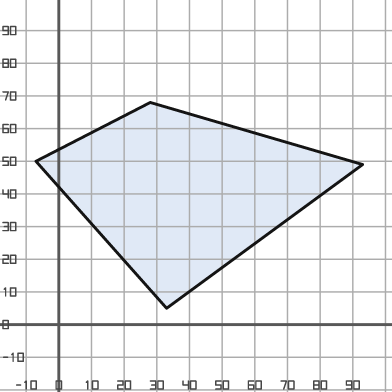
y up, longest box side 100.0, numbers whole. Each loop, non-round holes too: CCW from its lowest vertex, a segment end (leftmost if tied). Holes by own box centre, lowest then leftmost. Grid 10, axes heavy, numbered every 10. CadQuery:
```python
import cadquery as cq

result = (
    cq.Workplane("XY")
    .moveTo(33.0, 5.0)
    .lineTo(93.0, 49.0)
    .lineTo(28.0, 68.0)
    .lineTo(-7.0, 50.0)
    .close()
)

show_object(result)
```